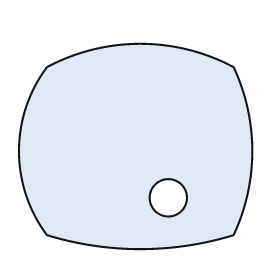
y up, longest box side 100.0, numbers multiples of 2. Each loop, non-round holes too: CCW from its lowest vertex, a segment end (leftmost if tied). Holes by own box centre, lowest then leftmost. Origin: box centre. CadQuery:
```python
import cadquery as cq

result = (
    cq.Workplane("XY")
    .moveTo(-38.0, -38.0)
    .threePointArc((2.0, -44.0), (42.0, -38.0))
    .threePointArc((50.0, -2.0), (42.0, 34.0))
    .threePointArc((2.0, 44.0), (-38.0, 34.0))
    .threePointArc((-50.0, -2.0), (-38.0, -38.0))
    .close()
    .moveTo(14.0, -22.0)
    .circle(8.0)
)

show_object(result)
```